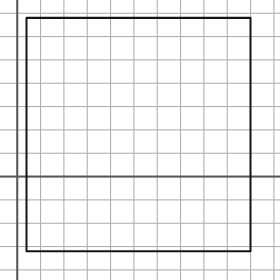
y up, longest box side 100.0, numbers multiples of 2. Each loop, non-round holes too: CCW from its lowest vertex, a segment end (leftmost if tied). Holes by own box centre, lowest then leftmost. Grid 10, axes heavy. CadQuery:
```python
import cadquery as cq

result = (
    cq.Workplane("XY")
    .moveTo(4.0, -32.0)
    .lineTo(100.0, -32.0)
    .lineTo(100.0, 68.0)
    .lineTo(4.0, 68.0)
    .close()
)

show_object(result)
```